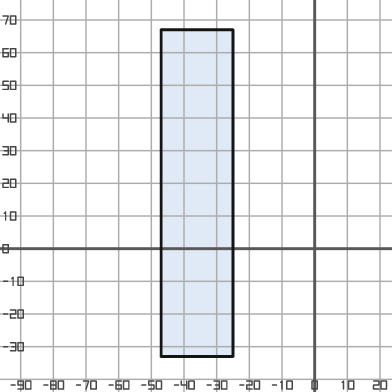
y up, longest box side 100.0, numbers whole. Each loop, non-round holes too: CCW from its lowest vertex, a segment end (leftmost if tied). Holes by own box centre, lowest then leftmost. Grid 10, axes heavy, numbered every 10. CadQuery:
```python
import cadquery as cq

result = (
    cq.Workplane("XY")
    .moveTo(-47.0, -33.0)
    .lineTo(-25.0, -33.0)
    .lineTo(-25.0, 67.0)
    .lineTo(-47.0, 67.0)
    .close()
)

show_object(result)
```